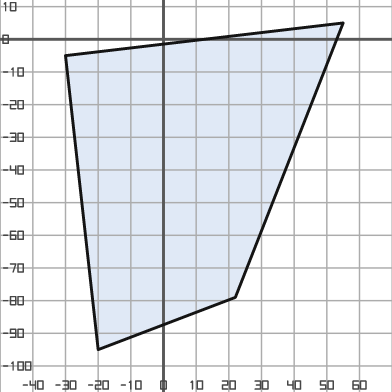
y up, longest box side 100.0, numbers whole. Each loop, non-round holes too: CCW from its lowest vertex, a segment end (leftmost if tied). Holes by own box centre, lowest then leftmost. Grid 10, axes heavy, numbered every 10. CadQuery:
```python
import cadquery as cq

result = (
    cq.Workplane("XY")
    .moveTo(-20.0, -95.0)
    .lineTo(22.0, -79.0)
    .lineTo(55.0, 5.0)
    .lineTo(-30.0, -5.0)
    .close()
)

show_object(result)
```